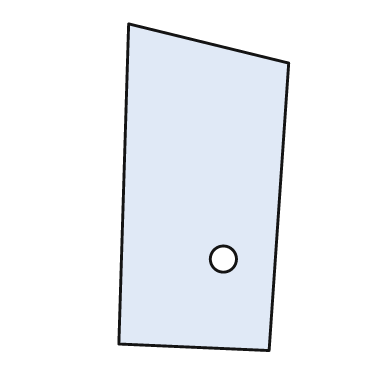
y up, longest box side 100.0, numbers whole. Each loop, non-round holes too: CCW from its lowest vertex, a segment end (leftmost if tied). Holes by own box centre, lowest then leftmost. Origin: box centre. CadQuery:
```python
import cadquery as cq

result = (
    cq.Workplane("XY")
    .moveTo(20.0, -50.0)
    .lineTo(26.0, 38.0)
    .lineTo(-23.0, 50.0)
    .lineTo(-26.0, -48.0)
    .close()
    .moveTo(6.0, -22.0)
    .circle(4.0)
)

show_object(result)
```